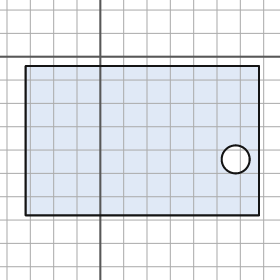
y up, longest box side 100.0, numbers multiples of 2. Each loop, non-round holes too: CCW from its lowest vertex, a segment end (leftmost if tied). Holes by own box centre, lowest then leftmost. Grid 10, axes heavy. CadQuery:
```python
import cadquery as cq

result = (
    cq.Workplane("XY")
    .moveTo(-32.0, -68.0)
    .lineTo(68.0, -68.0)
    .lineTo(68.0, -4.0)
    .lineTo(-32.0, -4.0)
    .close()
    .moveTo(58.0, -44.0)
    .circle(6.0)
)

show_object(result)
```